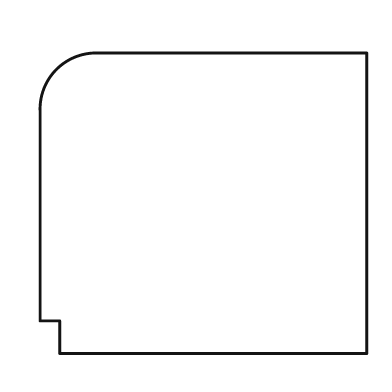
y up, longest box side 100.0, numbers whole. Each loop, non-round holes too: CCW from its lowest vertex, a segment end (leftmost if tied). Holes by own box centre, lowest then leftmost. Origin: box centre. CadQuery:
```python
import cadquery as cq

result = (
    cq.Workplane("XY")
    .moveTo(-44.0, -46.0)
    .lineTo(50.0, -46.0)
    .lineTo(50.0, 46.0)
    .lineTo(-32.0, 46.0)
    .threePointArc((-45.0, 41.0), (-50.0, 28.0))
    .lineTo(-50.0, -36.0)
    .lineTo(-44.0, -36.0)
    .close()
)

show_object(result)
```